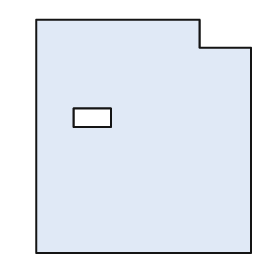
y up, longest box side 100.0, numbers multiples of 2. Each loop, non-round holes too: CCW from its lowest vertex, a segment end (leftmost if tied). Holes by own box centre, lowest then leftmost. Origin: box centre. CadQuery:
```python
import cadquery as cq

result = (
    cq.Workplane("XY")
    .moveTo(-46.0, -50.0)
    .lineTo(46.0, -50.0)
    .lineTo(46.0, 38.0)
    .lineTo(24.0, 38.0)
    .lineTo(24.0, 50.0)
    .lineTo(-46.0, 50.0)
    .close()
    .moveTo(-30.0, 4.0)
    .lineTo(-14.0, 4.0)
    .lineTo(-14.0, 12.0)
    .lineTo(-30.0, 12.0)
    .close()
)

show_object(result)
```